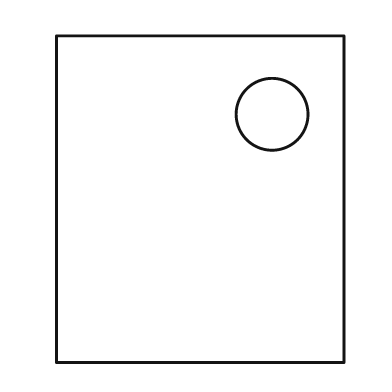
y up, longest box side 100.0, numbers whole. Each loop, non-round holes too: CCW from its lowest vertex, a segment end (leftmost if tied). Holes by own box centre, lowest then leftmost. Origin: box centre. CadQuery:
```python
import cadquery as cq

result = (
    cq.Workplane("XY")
    .moveTo(-44.0, -50.0)
    .lineTo(44.0, -50.0)
    .lineTo(44.0, 50.0)
    .lineTo(-44.0, 50.0)
    .close()
    .moveTo(22.0, 26.0)
    .circle(11.0)
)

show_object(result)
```